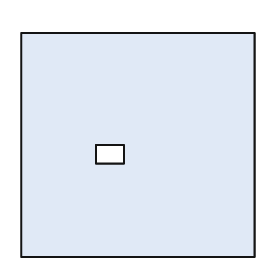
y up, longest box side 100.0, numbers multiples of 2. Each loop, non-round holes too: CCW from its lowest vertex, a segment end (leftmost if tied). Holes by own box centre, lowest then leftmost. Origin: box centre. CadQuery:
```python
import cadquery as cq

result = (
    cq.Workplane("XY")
    .moveTo(-50.0, -48.0)
    .lineTo(50.0, -48.0)
    .lineTo(50.0, 48.0)
    .lineTo(-50.0, 48.0)
    .close()
    .moveTo(-18.0, -8.0)
    .lineTo(-6.0, -8.0)
    .lineTo(-6.0, 0.0)
    .lineTo(-18.0, 0.0)
    .close()
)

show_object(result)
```